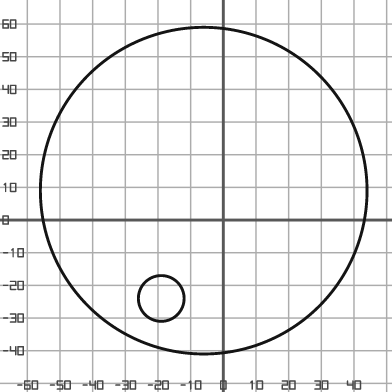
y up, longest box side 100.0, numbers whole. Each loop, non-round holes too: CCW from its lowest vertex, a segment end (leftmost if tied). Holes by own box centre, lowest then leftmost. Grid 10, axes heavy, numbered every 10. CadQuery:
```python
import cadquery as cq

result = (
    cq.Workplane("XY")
    .moveTo(-6.0, 9.0)
    .circle(50.0)
    .moveTo(-19.0, -24.0)
    .circle(7.0)
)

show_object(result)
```